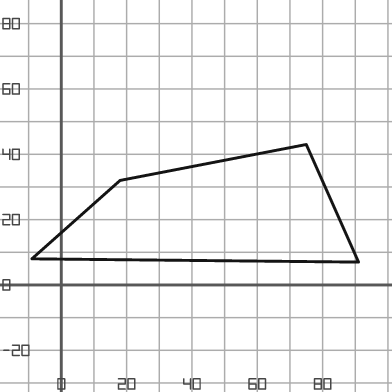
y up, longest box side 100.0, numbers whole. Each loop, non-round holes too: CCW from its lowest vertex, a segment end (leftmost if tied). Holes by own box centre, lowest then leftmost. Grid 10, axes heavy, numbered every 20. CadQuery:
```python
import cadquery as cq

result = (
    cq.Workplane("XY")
    .moveTo(91.0, 7.0)
    .lineTo(75.0, 43.0)
    .lineTo(18.0, 32.0)
    .lineTo(-9.0, 8.0)
    .close()
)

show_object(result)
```